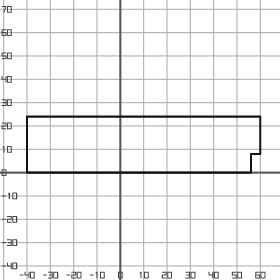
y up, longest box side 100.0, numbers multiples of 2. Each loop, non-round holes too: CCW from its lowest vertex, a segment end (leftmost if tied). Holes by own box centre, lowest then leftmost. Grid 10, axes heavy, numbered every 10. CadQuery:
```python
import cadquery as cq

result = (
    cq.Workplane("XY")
    .moveTo(-40.0, 0.0)
    .lineTo(56.0, 0.0)
    .lineTo(56.0, 8.0)
    .lineTo(60.0, 8.0)
    .lineTo(60.0, 24.0)
    .lineTo(-40.0, 24.0)
    .close()
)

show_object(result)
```